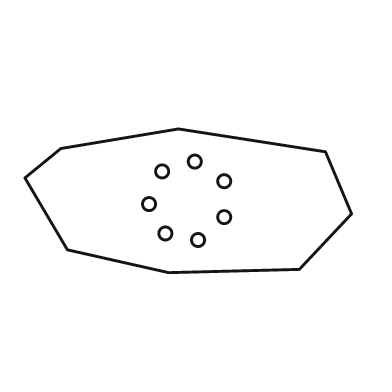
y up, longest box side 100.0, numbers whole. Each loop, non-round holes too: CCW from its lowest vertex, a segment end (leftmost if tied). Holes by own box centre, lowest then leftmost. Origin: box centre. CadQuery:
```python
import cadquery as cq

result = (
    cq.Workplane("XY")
    .moveTo(-6.0, -22.0)
    .lineTo(34.0, -21.0)
    .lineTo(50.0, -4.0)
    .lineTo(42.0, 15.0)
    .lineTo(-3.0, 22.0)
    .lineTo(-39.0, 16.0)
    .lineTo(-50.0, 7.0)
    .lineTo(-37.0, -15.0)
    .close()
    .moveTo(3.0, -12.0)
    .circle(2.0)
    .moveTo(-7.0, -10.0)
    .circle(2.0)
    .moveTo(11.0, -5.0)
    .circle(2.0)
    .moveTo(-12.0, -1.0)
    .circle(2.0)
    .moveTo(11.0, 6.0)
    .circle(2.0)
    .moveTo(-8.0, 9.0)
    .circle(2.0)
    .moveTo(2.0, 12.0)
    .circle(2.0)
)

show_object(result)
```